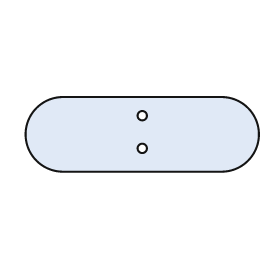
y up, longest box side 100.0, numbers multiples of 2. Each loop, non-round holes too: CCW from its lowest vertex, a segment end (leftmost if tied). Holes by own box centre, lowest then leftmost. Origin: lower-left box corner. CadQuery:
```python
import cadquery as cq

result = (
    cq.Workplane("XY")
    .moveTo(16.0, 0.0)
    .lineTo(84.0, 0.0)
    .threePointArc((100.0, 16.0), (84.0, 32.0))
    .lineTo(16.0, 32.0)
    .threePointArc((0.0, 16.0), (16.0, 0.0))
    .close()
    .moveTo(50.0, 10.0)
    .circle(2.0)
    .moveTo(50.0, 24.0)
    .circle(2.0)
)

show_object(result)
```